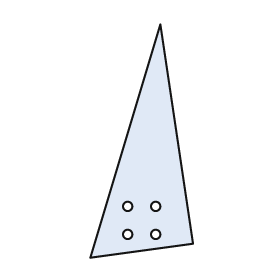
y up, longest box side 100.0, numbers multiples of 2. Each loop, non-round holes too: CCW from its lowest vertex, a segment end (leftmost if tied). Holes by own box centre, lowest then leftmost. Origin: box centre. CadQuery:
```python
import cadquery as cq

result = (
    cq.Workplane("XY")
    .moveTo(-22.0, -50.0)
    .lineTo(22.0, -44.0)
    .lineTo(8.0, 50.0)
    .close()
    .moveTo(-6.0, -40.0)
    .circle(2.0)
    .moveTo(6.0, -40.0)
    .circle(2.0)
    .moveTo(-6.0, -28.0)
    .circle(2.0)
    .moveTo(6.0, -28.0)
    .circle(2.0)
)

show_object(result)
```